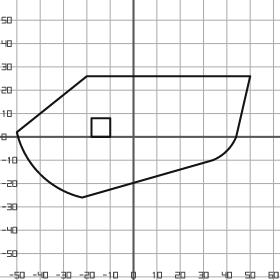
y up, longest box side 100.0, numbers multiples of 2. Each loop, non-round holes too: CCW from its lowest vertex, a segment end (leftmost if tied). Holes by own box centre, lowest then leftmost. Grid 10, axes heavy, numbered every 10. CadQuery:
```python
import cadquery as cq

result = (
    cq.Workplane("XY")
    .moveTo(-22.0, -26.0)
    .lineTo(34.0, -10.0)
    .threePointArc((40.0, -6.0), (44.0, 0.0))
    .lineTo(50.0, 26.0)
    .lineTo(-20.0, 26.0)
    .lineTo(-50.0, 2.0)
    .threePointArc((-40.0, -16.0), (-22.0, -26.0))
    .close()
    .moveTo(-18.0, 0.0)
    .lineTo(-10.0, 0.0)
    .lineTo(-10.0, 8.0)
    .lineTo(-18.0, 8.0)
    .close()
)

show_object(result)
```